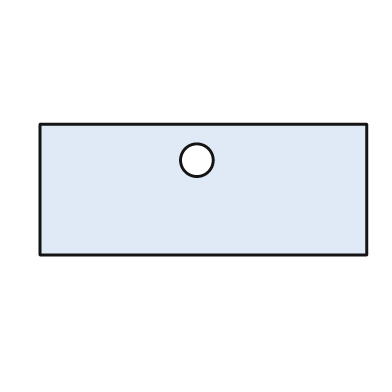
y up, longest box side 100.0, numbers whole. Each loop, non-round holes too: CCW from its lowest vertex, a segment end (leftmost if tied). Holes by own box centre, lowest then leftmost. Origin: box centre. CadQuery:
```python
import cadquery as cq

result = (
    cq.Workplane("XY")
    .moveTo(-50.0, -20.0)
    .lineTo(50.0, -20.0)
    .lineTo(50.0, 20.0)
    .lineTo(-50.0, 20.0)
    .close()
    .moveTo(-2.0, 9.0)
    .circle(5.0)
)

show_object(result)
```